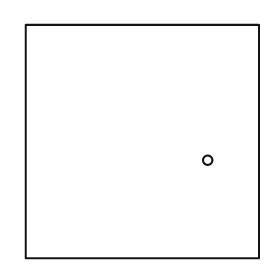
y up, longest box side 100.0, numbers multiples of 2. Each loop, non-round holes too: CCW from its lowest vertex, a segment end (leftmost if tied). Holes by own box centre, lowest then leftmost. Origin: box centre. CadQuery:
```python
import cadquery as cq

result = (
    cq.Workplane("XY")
    .moveTo(-50.0, -50.0)
    .lineTo(50.0, -50.0)
    .lineTo(50.0, 50.0)
    .lineTo(-50.0, 50.0)
    .close()
    .moveTo(28.0, -8.0)
    .circle(2.0)
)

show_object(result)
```